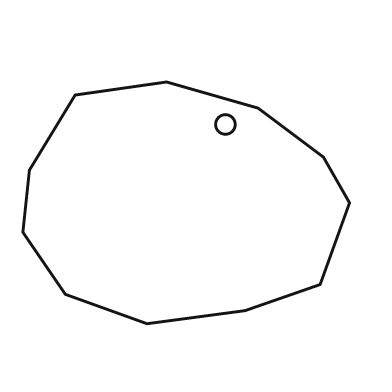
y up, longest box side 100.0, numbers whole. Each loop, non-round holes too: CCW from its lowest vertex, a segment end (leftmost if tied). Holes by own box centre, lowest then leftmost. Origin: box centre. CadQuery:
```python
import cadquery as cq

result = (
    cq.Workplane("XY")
    .moveTo(-12.0, -37.0)
    .lineTo(18.0, -33.0)
    .lineTo(41.0, -25.0)
    .lineTo(50.0, 0.0)
    .lineTo(42.0, 14.0)
    .lineTo(22.0, 29.0)
    .lineTo(-6.0, 37.0)
    .lineTo(-34.0, 33.0)
    .lineTo(-48.0, 10.0)
    .lineTo(-50.0, -9.0)
    .lineTo(-37.0, -28.0)
    .close()
    .moveTo(12.0, 24.0)
    .circle(3.0)
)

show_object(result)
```